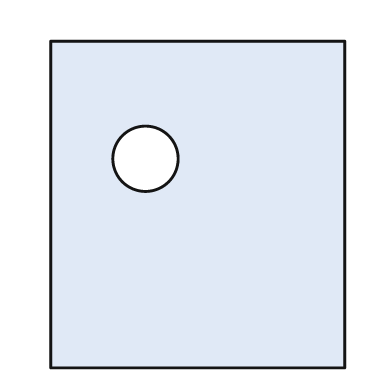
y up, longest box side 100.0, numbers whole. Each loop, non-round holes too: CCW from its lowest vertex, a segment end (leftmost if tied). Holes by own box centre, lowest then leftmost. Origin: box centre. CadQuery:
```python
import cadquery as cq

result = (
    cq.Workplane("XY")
    .moveTo(-45.0, -50.0)
    .lineTo(45.0, -50.0)
    .lineTo(45.0, 50.0)
    .lineTo(-45.0, 50.0)
    .close()
    .moveTo(-16.0, 14.0)
    .circle(10.0)
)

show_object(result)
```